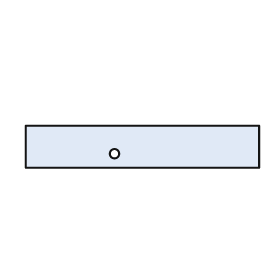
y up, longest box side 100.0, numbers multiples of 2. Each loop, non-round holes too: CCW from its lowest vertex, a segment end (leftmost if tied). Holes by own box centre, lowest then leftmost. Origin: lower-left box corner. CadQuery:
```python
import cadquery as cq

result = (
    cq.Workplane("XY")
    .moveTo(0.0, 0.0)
    .lineTo(100.0, 0.0)
    .lineTo(100.0, 18.0)
    .lineTo(0.0, 18.0)
    .close()
    .moveTo(38.0, 6.0)
    .circle(2.0)
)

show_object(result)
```